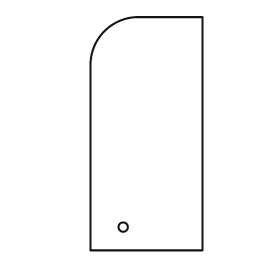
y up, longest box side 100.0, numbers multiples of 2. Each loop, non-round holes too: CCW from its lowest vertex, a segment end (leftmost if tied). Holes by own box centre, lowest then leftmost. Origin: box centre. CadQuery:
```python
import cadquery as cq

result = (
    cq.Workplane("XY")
    .moveTo(-24.0, -50.0)
    .lineTo(24.0, -50.0)
    .lineTo(24.0, 50.0)
    .lineTo(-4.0, 50.0)
    .threePointArc((-18.0, 44.0), (-24.0, 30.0))
    .close()
    .moveTo(-10.0, -40.0)
    .circle(2.0)
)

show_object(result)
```